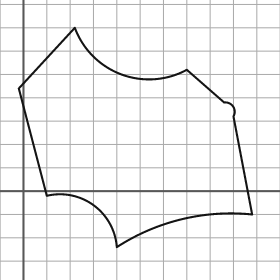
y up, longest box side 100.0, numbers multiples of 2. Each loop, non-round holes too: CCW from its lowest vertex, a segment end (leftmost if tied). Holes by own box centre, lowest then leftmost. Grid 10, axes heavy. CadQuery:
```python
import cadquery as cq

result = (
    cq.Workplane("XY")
    .moveTo(40.0, -24.0)
    .threePointArc((68.0, -12.0), (98.0, -10.0))
    .lineTo(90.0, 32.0)
    .threePointArc((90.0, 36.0), (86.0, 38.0))
    .lineTo(70.0, 52.0)
    .threePointArc((42.0, 50.0), (22.0, 70.0))
    .lineTo(-2.0, 44.0)
    .lineTo(10.0, -2.0)
    .threePointArc((30.0, -6.0), (40.0, -24.0))
    .close()
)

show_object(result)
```